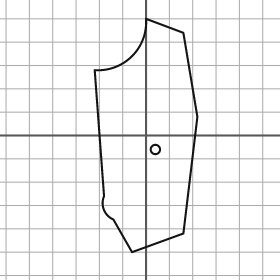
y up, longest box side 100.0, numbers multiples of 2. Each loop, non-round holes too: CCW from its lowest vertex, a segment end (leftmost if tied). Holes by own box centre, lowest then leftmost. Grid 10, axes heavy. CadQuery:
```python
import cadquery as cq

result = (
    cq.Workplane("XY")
    .moveTo(-6.0, -50.0)
    .lineTo(16.0, -42.0)
    .lineTo(22.0, 8.0)
    .lineTo(16.0, 44.0)
    .lineTo(0.0, 50.0)
    .threePointArc((-6.0, 34.0), (-22.0, 28.0))
    .lineTo(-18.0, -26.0)
    .threePointArc((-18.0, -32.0), (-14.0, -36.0))
    .close()
    .moveTo(4.0, -6.0)
    .circle(2.0)
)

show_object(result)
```